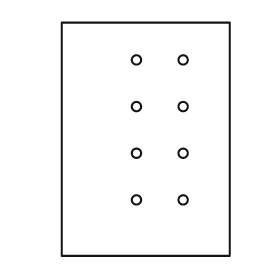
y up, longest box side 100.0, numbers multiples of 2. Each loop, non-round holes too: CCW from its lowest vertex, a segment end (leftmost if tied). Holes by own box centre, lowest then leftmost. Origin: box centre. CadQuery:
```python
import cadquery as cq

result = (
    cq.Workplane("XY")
    .moveTo(-36.0, -50.0)
    .lineTo(36.0, -50.0)
    .lineTo(36.0, 50.0)
    .lineTo(-36.0, 50.0)
    .close()
    .moveTo(-4.0, -26.0)
    .circle(2.0)
    .moveTo(16.0, -26.0)
    .circle(2.0)
    .moveTo(-4.0, -6.0)
    .circle(2.0)
    .moveTo(16.0, -6.0)
    .circle(2.0)
    .moveTo(-4.0, 14.0)
    .circle(2.0)
    .moveTo(16.0, 14.0)
    .circle(2.0)
    .moveTo(-4.0, 34.0)
    .circle(2.0)
    .moveTo(16.0, 34.0)
    .circle(2.0)
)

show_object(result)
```